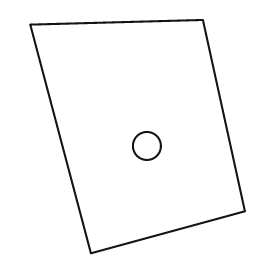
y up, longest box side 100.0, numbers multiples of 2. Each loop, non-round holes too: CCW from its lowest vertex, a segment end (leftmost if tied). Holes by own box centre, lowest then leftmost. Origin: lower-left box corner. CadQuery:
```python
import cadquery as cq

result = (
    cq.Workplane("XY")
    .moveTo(26.0, 0.0)
    .lineTo(92.0, 18.0)
    .lineTo(74.0, 100.0)
    .lineTo(0.0, 98.0)
    .close()
    .moveTo(50.0, 46.0)
    .circle(6.0)
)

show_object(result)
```